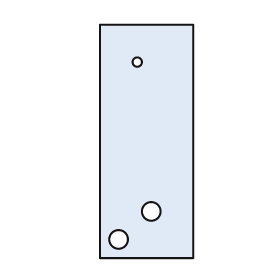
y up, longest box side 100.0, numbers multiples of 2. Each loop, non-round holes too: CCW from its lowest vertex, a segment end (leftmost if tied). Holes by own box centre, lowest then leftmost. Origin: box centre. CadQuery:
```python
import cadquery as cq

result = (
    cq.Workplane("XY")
    .moveTo(-20.0, -50.0)
    .lineTo(20.0, -50.0)
    .lineTo(20.0, 50.0)
    .lineTo(-20.0, 50.0)
    .close()
    .moveTo(-12.0, -42.0)
    .circle(4.0)
    .moveTo(2.0, -30.0)
    .circle(4.0)
    .moveTo(-4.0, 34.0)
    .circle(2.0)
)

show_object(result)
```